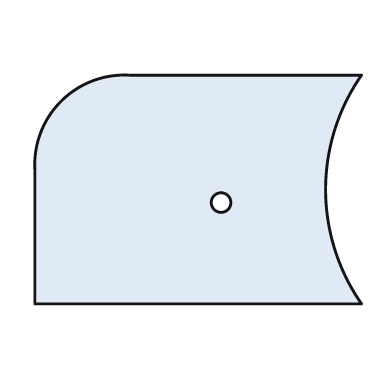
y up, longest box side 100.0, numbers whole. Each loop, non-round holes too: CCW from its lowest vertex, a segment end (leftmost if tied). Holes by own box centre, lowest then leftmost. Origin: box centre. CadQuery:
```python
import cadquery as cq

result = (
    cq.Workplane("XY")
    .moveTo(-50.0, -35.0)
    .lineTo(50.0, -35.0)
    .threePointArc((39.0, 0.0), (50.0, 35.0))
    .lineTo(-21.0, 35.0)
    .threePointArc((-42.0, 27.0), (-50.0, 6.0))
    .close()
    .moveTo(7.0, -4.0)
    .circle(3.0)
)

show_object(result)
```